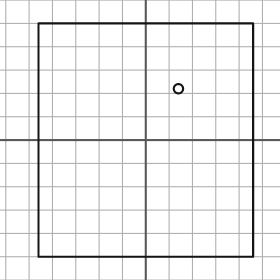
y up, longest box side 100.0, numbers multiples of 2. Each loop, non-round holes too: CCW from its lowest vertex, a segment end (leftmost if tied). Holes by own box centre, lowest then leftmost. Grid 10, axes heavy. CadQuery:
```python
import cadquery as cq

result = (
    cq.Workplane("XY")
    .moveTo(-46.0, -50.0)
    .lineTo(46.0, -50.0)
    .lineTo(46.0, 50.0)
    .lineTo(-46.0, 50.0)
    .close()
    .moveTo(14.0, 22.0)
    .circle(2.0)
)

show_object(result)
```